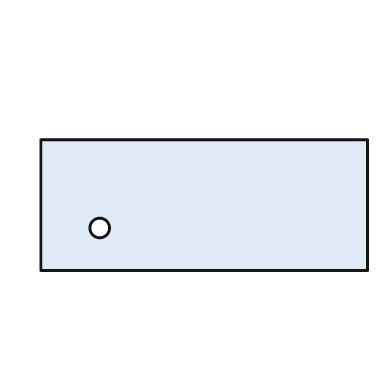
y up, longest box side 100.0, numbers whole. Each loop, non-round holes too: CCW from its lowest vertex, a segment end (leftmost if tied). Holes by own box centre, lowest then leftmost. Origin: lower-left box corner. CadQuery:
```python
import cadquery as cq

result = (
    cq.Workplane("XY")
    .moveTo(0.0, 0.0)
    .lineTo(100.0, 0.0)
    .lineTo(100.0, 40.0)
    .lineTo(0.0, 40.0)
    .close()
    .moveTo(18.0, 13.0)
    .circle(3.0)
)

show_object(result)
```